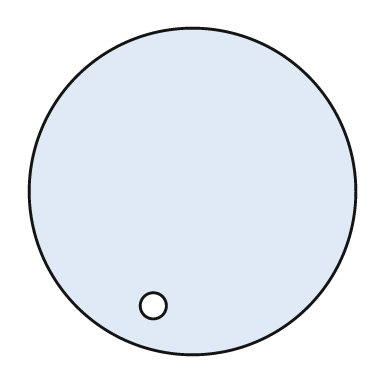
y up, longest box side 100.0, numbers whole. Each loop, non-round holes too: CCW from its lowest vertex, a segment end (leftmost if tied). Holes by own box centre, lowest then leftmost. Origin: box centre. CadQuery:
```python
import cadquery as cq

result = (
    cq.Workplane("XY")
    .moveTo(0.0, 0.0)
    .circle(50.0)
    .moveTo(-12.0, -35.0)
    .circle(4.0)
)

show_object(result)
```